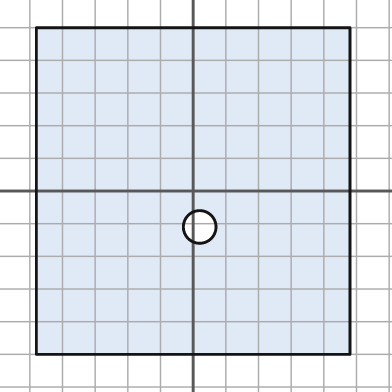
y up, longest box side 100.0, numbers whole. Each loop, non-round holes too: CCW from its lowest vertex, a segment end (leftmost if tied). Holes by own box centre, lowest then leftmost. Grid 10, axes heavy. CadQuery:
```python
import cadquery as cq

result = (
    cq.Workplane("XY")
    .moveTo(-48.0, -50.0)
    .lineTo(48.0, -50.0)
    .lineTo(48.0, 50.0)
    .lineTo(-48.0, 50.0)
    .close()
    .moveTo(2.0, -11.0)
    .circle(5.0)
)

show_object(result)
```